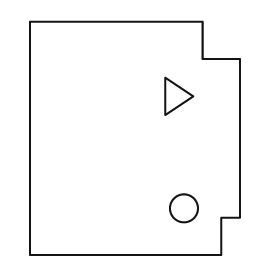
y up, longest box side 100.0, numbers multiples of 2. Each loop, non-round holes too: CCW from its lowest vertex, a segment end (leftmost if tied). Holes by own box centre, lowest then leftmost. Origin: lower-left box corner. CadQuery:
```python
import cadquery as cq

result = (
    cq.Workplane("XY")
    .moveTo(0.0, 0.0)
    .lineTo(82.0, 0.0)
    .lineTo(82.0, 16.0)
    .lineTo(90.0, 16.0)
    .lineTo(90.0, 84.0)
    .lineTo(74.0, 84.0)
    .lineTo(74.0, 100.0)
    .lineTo(0.0, 100.0)
    .close()
    .moveTo(66.0, 20.0)
    .circle(6.0)
    .moveTo(58.0, 60.0)
    .lineTo(70.0, 68.0)
    .lineTo(58.0, 76.0)
    .close()
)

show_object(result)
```